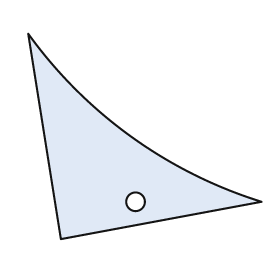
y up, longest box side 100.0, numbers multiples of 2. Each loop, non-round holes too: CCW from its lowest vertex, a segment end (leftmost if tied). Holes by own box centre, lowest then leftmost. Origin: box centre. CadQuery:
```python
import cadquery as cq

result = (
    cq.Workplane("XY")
    .moveTo(-36.0, -44.0)
    .lineTo(50.0, -28.0)
    .threePointArc((-6.0, 0.0), (-50.0, 44.0))
    .close()
    .moveTo(-4.0, -28.0)
    .circle(4.0)
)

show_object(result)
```